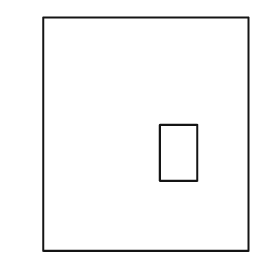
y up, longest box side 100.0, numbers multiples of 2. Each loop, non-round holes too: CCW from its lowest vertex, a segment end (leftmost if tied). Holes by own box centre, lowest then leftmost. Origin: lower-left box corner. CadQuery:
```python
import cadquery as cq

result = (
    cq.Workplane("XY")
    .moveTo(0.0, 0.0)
    .lineTo(88.0, 0.0)
    .lineTo(88.0, 100.0)
    .lineTo(0.0, 100.0)
    .close()
    .moveTo(50.0, 30.0)
    .lineTo(66.0, 30.0)
    .lineTo(66.0, 54.0)
    .lineTo(50.0, 54.0)
    .close()
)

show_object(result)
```